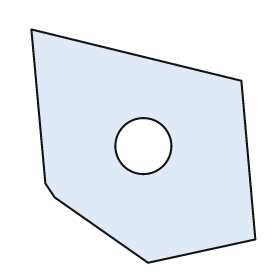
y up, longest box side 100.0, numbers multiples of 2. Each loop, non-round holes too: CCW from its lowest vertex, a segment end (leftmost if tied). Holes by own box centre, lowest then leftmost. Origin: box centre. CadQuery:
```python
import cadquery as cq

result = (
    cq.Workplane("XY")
    .moveTo(2.0, -50.0)
    .lineTo(48.0, -40.0)
    .lineTo(42.0, 28.0)
    .lineTo(-48.0, 50.0)
    .lineTo(-42.0, -16.0)
    .lineTo(-38.0, -22.0)
    .close()
    .moveTo(0.0, 0.0)
    .circle(12.0)
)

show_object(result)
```